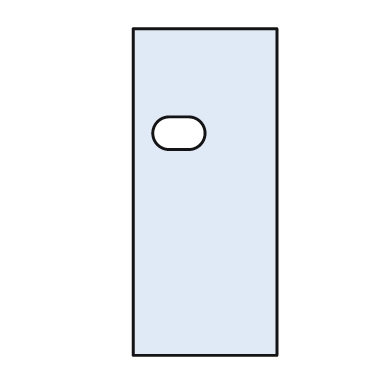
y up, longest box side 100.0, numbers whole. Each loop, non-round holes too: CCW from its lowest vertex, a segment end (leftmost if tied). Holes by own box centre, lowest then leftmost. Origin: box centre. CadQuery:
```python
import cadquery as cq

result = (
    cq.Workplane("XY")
    .moveTo(-22.0, -50.0)
    .lineTo(22.0, -50.0)
    .lineTo(22.0, 50.0)
    .lineTo(-22.0, 50.0)
    .close()
    .moveTo(-11.0, 13.0)
    .lineTo(-5.0, 13.0)
    .threePointArc((0.0, 18.0), (-5.0, 23.0))
    .lineTo(-11.0, 23.0)
    .threePointArc((-16.0, 18.0), (-11.0, 13.0))
    .close()
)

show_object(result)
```